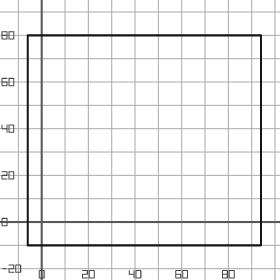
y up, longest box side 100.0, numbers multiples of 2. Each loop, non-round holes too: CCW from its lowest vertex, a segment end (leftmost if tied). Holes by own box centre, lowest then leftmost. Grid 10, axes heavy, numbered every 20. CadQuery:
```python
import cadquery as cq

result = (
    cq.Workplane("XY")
    .moveTo(-6.0, -10.0)
    .lineTo(94.0, -10.0)
    .lineTo(94.0, 80.0)
    .lineTo(-6.0, 80.0)
    .close()
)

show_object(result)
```